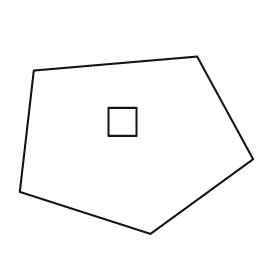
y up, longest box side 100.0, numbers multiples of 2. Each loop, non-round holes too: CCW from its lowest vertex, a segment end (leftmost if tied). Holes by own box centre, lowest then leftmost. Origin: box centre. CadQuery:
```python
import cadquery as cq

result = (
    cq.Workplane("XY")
    .moveTo(6.0, -38.0)
    .lineTo(50.0, -6.0)
    .lineTo(26.0, 38.0)
    .lineTo(-44.0, 32.0)
    .lineTo(-50.0, -20.0)
    .close()
    .moveTo(-12.0, 4.0)
    .lineTo(0.0, 4.0)
    .lineTo(0.0, 16.0)
    .lineTo(-12.0, 16.0)
    .close()
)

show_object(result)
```